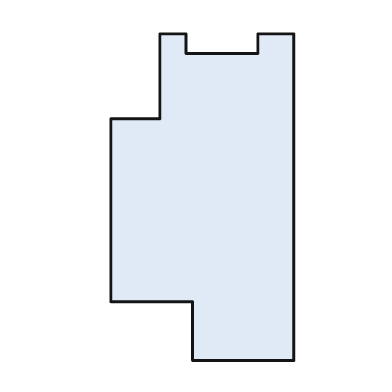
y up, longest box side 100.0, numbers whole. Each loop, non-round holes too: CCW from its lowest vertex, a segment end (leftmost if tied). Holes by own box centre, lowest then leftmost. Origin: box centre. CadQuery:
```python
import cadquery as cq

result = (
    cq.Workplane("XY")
    .moveTo(-3.0, -50.0)
    .lineTo(28.0, -50.0)
    .lineTo(28.0, 50.0)
    .lineTo(17.0, 50.0)
    .lineTo(17.0, 44.0)
    .lineTo(-5.0, 44.0)
    .lineTo(-5.0, 50.0)
    .lineTo(-13.0, 50.0)
    .lineTo(-13.0, 24.0)
    .lineTo(-28.0, 24.0)
    .lineTo(-28.0, -32.0)
    .lineTo(-3.0, -32.0)
    .close()
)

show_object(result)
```